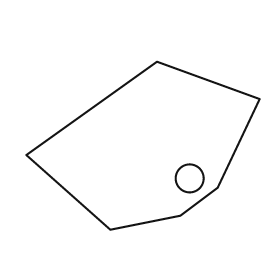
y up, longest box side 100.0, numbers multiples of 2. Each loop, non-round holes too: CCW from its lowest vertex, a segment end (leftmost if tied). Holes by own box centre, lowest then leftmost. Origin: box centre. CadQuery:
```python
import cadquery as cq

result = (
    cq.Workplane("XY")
    .moveTo(-14.0, -36.0)
    .lineTo(16.0, -30.0)
    .lineTo(32.0, -18.0)
    .lineTo(50.0, 20.0)
    .lineTo(6.0, 36.0)
    .lineTo(-50.0, -4.0)
    .close()
    .moveTo(20.0, -14.0)
    .circle(6.0)
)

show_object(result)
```